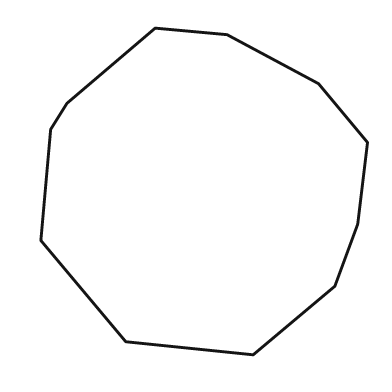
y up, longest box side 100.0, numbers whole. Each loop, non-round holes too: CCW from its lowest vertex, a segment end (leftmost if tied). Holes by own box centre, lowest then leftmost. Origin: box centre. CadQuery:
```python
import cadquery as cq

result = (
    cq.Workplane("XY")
    .moveTo(15.0, -50.0)
    .lineTo(40.0, -29.0)
    .lineTo(47.0, -10.0)
    .lineTo(50.0, 15.0)
    .lineTo(35.0, 33.0)
    .lineTo(7.0, 48.0)
    .lineTo(-15.0, 50.0)
    .lineTo(-42.0, 27.0)
    .lineTo(-47.0, 19.0)
    .lineTo(-50.0, -15.0)
    .lineTo(-24.0, -46.0)
    .close()
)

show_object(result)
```